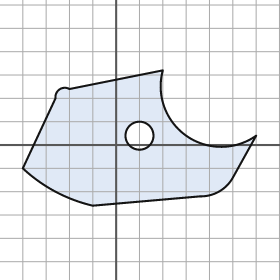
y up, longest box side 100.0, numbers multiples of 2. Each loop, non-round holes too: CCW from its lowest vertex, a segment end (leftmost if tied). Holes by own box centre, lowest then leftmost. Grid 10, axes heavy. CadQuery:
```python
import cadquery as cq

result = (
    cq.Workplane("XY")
    .moveTo(-10.0, -26.0)
    .lineTo(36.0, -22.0)
    .threePointArc((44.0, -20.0), (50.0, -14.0))
    .lineTo(60.0, 4.0)
    .threePointArc((30.0, 4.0), (20.0, 32.0))
    .lineTo(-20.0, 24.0)
    .threePointArc((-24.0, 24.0), (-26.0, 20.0))
    .lineTo(-40.0, -10.0)
    .threePointArc((-26.0, -20.0), (-10.0, -26.0))
    .close()
    .moveTo(10.0, 4.0)
    .circle(6.0)
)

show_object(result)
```